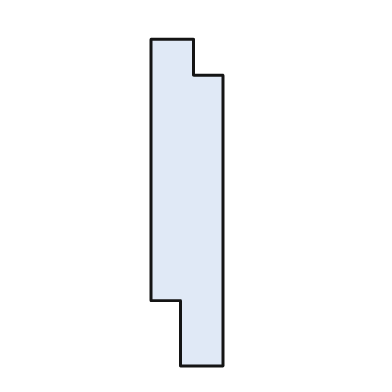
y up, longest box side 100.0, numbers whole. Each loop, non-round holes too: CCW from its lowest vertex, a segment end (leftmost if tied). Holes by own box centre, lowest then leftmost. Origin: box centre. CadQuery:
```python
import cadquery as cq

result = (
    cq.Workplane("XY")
    .moveTo(-2.0, -50.0)
    .lineTo(11.0, -50.0)
    .lineTo(11.0, 39.0)
    .lineTo(2.0, 39.0)
    .lineTo(2.0, 50.0)
    .lineTo(-11.0, 50.0)
    .lineTo(-11.0, -30.0)
    .lineTo(-2.0, -30.0)
    .close()
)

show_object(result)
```